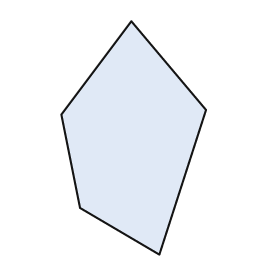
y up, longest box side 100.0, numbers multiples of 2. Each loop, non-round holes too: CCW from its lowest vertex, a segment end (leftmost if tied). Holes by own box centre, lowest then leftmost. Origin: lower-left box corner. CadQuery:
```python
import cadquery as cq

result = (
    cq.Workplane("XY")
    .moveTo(42.0, 0.0)
    .lineTo(62.0, 62.0)
    .lineTo(30.0, 100.0)
    .lineTo(0.0, 60.0)
    .lineTo(8.0, 20.0)
    .close()
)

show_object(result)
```